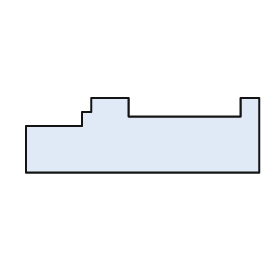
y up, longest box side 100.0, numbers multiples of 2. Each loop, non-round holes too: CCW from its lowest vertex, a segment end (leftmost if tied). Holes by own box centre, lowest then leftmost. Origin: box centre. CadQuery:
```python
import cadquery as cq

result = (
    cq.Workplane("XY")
    .moveTo(-50.0, -16.0)
    .lineTo(50.0, -16.0)
    .lineTo(50.0, 16.0)
    .lineTo(42.0, 16.0)
    .lineTo(42.0, 8.0)
    .lineTo(-6.0, 8.0)
    .lineTo(-6.0, 16.0)
    .lineTo(-22.0, 16.0)
    .lineTo(-22.0, 10.0)
    .lineTo(-26.0, 10.0)
    .lineTo(-26.0, 4.0)
    .lineTo(-50.0, 4.0)
    .close()
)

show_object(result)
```